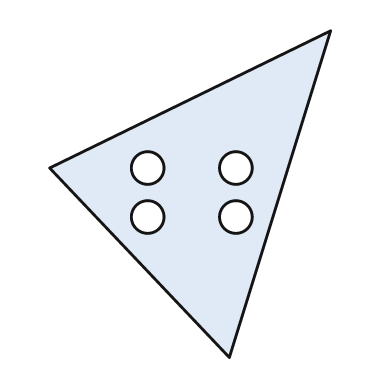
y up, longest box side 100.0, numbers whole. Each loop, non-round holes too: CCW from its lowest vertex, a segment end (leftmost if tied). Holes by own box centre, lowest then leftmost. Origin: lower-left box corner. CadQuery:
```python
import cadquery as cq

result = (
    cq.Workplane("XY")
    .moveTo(55.0, 0.0)
    .lineTo(86.0, 100.0)
    .lineTo(0.0, 58.0)
    .close()
    .moveTo(30.0, 43.0)
    .circle(5.0)
    .moveTo(57.0, 43.0)
    .circle(5.0)
    .moveTo(30.0, 58.0)
    .circle(5.0)
    .moveTo(57.0, 58.0)
    .circle(5.0)
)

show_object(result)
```